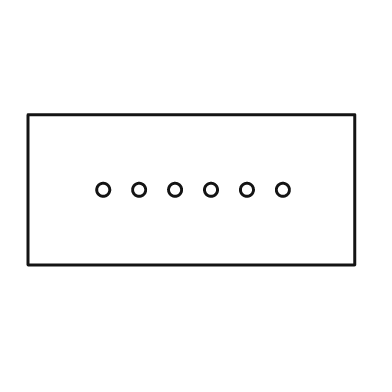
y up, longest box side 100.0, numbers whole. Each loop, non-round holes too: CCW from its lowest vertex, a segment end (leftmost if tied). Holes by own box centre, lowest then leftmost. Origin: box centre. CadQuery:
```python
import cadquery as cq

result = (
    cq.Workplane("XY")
    .moveTo(-50.0, -23.0)
    .lineTo(50.0, -23.0)
    .lineTo(50.0, 23.0)
    .lineTo(-50.0, 23.0)
    .close()
    .moveTo(-27.0, 0.0)
    .circle(2.0)
    .moveTo(-16.0, 0.0)
    .circle(2.0)
    .moveTo(-5.0, 0.0)
    .circle(2.0)
    .moveTo(6.0, 0.0)
    .circle(2.0)
    .moveTo(17.0, 0.0)
    .circle(2.0)
    .moveTo(28.0, 0.0)
    .circle(2.0)
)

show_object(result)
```